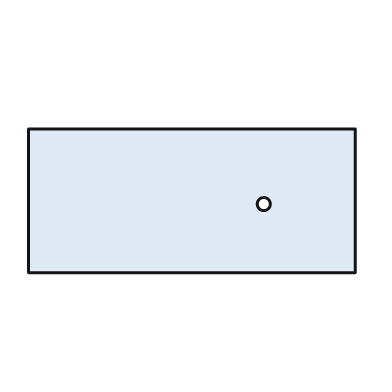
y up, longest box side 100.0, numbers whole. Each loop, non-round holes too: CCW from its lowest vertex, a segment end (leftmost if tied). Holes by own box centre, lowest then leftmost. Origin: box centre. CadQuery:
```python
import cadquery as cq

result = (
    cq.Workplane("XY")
    .moveTo(-50.0, -22.0)
    .lineTo(50.0, -22.0)
    .lineTo(50.0, 22.0)
    .lineTo(-50.0, 22.0)
    .close()
    .moveTo(22.0, -1.0)
    .circle(2.0)
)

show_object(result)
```